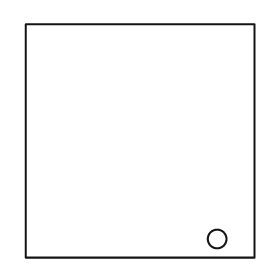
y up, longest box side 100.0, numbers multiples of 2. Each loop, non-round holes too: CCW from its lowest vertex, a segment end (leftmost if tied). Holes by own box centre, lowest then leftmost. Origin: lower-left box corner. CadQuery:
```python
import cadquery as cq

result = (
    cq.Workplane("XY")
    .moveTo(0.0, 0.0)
    .lineTo(98.0, 0.0)
    .lineTo(98.0, 100.0)
    .lineTo(0.0, 100.0)
    .close()
    .moveTo(82.0, 8.0)
    .circle(4.0)
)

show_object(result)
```